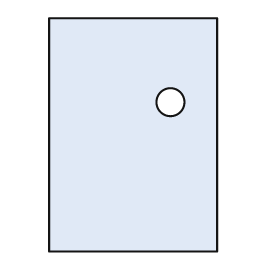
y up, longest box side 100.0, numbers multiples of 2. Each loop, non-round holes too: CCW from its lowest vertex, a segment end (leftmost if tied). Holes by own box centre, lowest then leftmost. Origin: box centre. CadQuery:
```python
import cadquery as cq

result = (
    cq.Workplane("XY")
    .moveTo(-36.0, -50.0)
    .lineTo(36.0, -50.0)
    .lineTo(36.0, 50.0)
    .lineTo(-36.0, 50.0)
    .close()
    .moveTo(16.0, 14.0)
    .circle(6.0)
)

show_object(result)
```